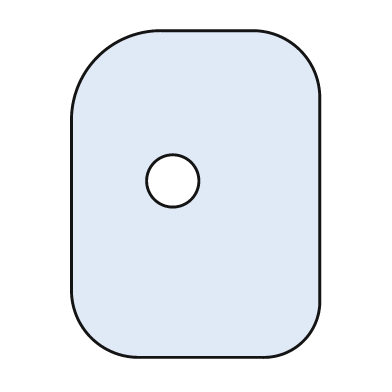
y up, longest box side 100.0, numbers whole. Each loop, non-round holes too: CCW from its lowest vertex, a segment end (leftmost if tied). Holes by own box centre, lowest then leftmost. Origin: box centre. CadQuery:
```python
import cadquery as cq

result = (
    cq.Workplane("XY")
    .moveTo(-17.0, -50.0)
    .lineTo(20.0, -50.0)
    .threePointArc((33.0, -45.0), (38.0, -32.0))
    .lineTo(38.0, 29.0)
    .threePointArc((32.0, 44.0), (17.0, 50.0))
    .lineTo(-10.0, 50.0)
    .threePointArc((-30.0, 42.0), (-38.0, 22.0))
    .lineTo(-38.0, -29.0)
    .threePointArc((-32.0, -44.0), (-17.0, -50.0))
    .close()
    .moveTo(-7.0, 4.0)
    .circle(8.0)
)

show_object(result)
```